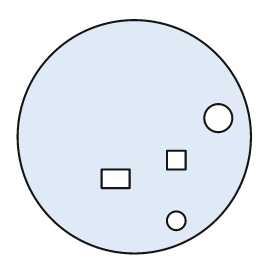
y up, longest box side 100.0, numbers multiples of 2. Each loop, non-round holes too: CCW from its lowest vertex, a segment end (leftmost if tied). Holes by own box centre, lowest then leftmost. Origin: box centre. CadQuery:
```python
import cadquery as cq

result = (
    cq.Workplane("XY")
    .moveTo(0.0, 0.0)
    .circle(50.0)
    .moveTo(18.0, -36.0)
    .circle(4.0)
    .moveTo(-14.0, -22.0)
    .lineTo(-2.0, -22.0)
    .lineTo(-2.0, -14.0)
    .lineTo(-14.0, -14.0)
    .close()
    .moveTo(14.0, -14.0)
    .lineTo(22.0, -14.0)
    .lineTo(22.0, -6.0)
    .lineTo(14.0, -6.0)
    .close()
    .moveTo(36.0, 8.0)
    .circle(6.0)
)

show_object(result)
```